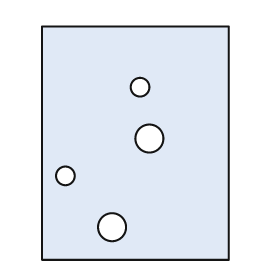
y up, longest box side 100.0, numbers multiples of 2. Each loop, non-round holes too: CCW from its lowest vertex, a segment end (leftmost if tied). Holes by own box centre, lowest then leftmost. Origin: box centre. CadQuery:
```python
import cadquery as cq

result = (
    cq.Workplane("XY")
    .moveTo(-40.0, -50.0)
    .lineTo(40.0, -50.0)
    .lineTo(40.0, 50.0)
    .lineTo(-40.0, 50.0)
    .close()
    .moveTo(-10.0, -36.0)
    .circle(6.0)
    .moveTo(-30.0, -14.0)
    .circle(4.0)
    .moveTo(6.0, 2.0)
    .circle(6.0)
    .moveTo(2.0, 24.0)
    .circle(4.0)
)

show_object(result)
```